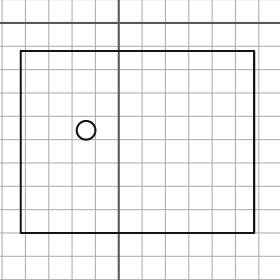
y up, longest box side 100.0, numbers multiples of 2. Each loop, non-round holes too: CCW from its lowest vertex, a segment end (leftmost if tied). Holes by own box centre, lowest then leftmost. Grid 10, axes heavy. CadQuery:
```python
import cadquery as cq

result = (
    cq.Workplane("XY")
    .moveTo(-42.0, -90.0)
    .lineTo(58.0, -90.0)
    .lineTo(58.0, -12.0)
    .lineTo(-42.0, -12.0)
    .close()
    .moveTo(-14.0, -46.0)
    .circle(4.0)
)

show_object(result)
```